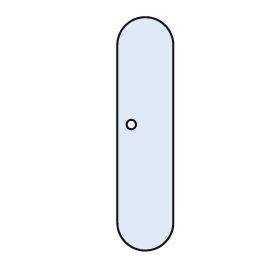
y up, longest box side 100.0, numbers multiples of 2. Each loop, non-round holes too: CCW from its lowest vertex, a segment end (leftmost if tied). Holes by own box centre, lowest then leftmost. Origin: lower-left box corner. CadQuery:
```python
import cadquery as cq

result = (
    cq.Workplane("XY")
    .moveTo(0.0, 12.0)
    .threePointArc((12.0, 0.0), (24.0, 12.0))
    .lineTo(24.0, 88.0)
    .threePointArc((12.0, 100.0), (0.0, 88.0))
    .close()
    .moveTo(6.0, 54.0)
    .circle(2.0)
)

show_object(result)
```